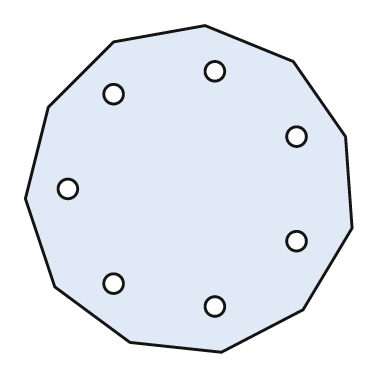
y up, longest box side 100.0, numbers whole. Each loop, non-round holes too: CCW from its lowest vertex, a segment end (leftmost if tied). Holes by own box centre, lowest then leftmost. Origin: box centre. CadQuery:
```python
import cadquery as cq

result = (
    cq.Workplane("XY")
    .moveTo(10.0, -50.0)
    .lineTo(35.0, -37.0)
    .lineTo(50.0, -12.0)
    .lineTo(48.0, 16.0)
    .lineTo(32.0, 39.0)
    .lineTo(5.0, 50.0)
    .lineTo(-23.0, 45.0)
    .lineTo(-43.0, 25.0)
    .lineTo(-50.0, -3.0)
    .lineTo(-41.0, -30.0)
    .lineTo(-18.0, -47.0)
    .close()
    .moveTo(8.0, -36.0)
    .circle(3.0)
    .moveTo(-23.0, -29.0)
    .circle(3.0)
    .moveTo(33.0, -16.0)
    .circle(3.0)
    .moveTo(-37.0, 0.0)
    .circle(3.0)
    .moveTo(33.0, 16.0)
    .circle(3.0)
    .moveTo(-23.0, 29.0)
    .circle(3.0)
    .moveTo(8.0, 36.0)
    .circle(3.0)
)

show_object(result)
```